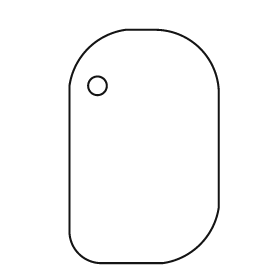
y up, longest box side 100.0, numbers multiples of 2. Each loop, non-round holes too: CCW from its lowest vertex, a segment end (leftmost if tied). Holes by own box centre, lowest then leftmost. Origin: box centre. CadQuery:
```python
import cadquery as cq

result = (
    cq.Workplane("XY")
    .moveTo(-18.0, -50.0)
    .lineTo(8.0, -50.0)
    .threePointArc((24.0, -42.0), (32.0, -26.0))
    .lineTo(32.0, 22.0)
    .threePointArc((24.0, 42.0), (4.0, 50.0))
    .lineTo(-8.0, 50.0)
    .threePointArc((-24.0, 42.0), (-32.0, 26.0))
    .lineTo(-32.0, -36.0)
    .threePointArc((-28.0, -46.0), (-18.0, -50.0))
    .close()
    .moveTo(-20.0, 26.0)
    .circle(4.0)
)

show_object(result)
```